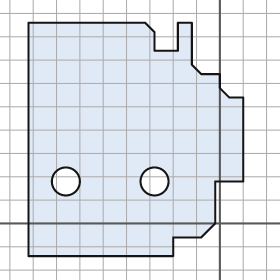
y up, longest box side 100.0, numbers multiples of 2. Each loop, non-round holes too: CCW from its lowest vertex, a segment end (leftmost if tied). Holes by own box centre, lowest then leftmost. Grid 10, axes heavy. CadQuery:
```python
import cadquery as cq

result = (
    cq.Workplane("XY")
    .moveTo(-82.0, -14.0)
    .lineTo(-20.0, -14.0)
    .lineTo(-20.0, -6.0)
    .lineTo(-8.0, -6.0)
    .lineTo(-2.0, 0.0)
    .lineTo(-2.0, 18.0)
    .lineTo(10.0, 18.0)
    .lineTo(10.0, 54.0)
    .lineTo(4.0, 54.0)
    .lineTo(0.0, 58.0)
    .lineTo(0.0, 64.0)
    .lineTo(-8.0, 64.0)
    .lineTo(-12.0, 68.0)
    .lineTo(-12.0, 86.0)
    .lineTo(-18.0, 86.0)
    .lineTo(-18.0, 74.0)
    .lineTo(-28.0, 74.0)
    .lineTo(-28.0, 82.0)
    .lineTo(-32.0, 86.0)
    .lineTo(-82.0, 86.0)
    .close()
    .moveTo(-66.0, 18.0)
    .circle(6.0)
    .moveTo(-28.0, 18.0)
    .circle(6.0)
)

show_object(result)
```